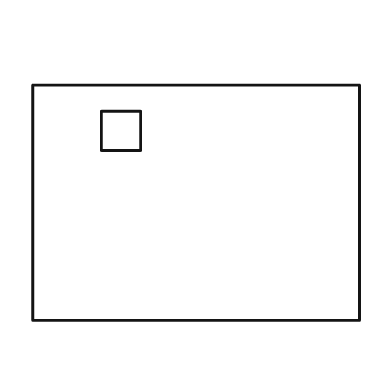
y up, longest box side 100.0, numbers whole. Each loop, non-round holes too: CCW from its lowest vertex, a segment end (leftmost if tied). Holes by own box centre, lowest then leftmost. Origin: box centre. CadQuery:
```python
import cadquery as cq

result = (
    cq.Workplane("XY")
    .moveTo(-50.0, -36.0)
    .lineTo(50.0, -36.0)
    .lineTo(50.0, 36.0)
    .lineTo(-50.0, 36.0)
    .close()
    .moveTo(-29.0, 16.0)
    .lineTo(-17.0, 16.0)
    .lineTo(-17.0, 28.0)
    .lineTo(-29.0, 28.0)
    .close()
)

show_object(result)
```